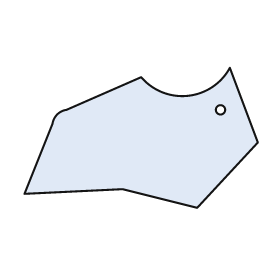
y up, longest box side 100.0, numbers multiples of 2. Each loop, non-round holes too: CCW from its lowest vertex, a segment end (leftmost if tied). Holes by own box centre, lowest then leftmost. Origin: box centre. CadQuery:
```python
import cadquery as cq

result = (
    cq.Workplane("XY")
    .moveTo(24.0, -30.0)
    .lineTo(50.0, -2.0)
    .lineTo(38.0, 30.0)
    .threePointArc((20.0, 18.0), (0.0, 26.0))
    .lineTo(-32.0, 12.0)
    .threePointArc((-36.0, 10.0), (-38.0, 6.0))
    .lineTo(-50.0, -24.0)
    .lineTo(-8.0, -22.0)
    .close()
    .moveTo(34.0, 12.0)
    .circle(2.0)
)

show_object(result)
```